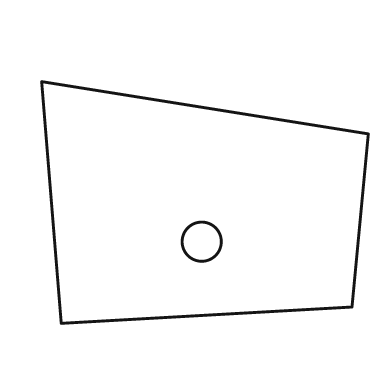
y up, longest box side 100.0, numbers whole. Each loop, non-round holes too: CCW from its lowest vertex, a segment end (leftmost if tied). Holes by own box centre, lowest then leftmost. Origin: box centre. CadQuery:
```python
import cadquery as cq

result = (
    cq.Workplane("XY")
    .moveTo(-44.0, -37.0)
    .lineTo(45.0, -32.0)
    .lineTo(50.0, 21.0)
    .lineTo(-50.0, 37.0)
    .close()
    .moveTo(-1.0, -12.0)
    .circle(6.0)
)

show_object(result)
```